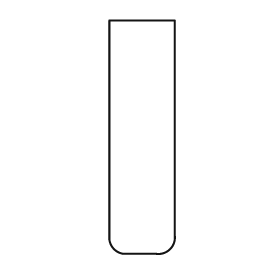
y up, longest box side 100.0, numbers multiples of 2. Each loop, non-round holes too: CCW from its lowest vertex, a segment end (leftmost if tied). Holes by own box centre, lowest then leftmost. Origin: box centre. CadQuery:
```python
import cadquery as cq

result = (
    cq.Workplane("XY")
    .moveTo(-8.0, -50.0)
    .lineTo(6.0, -50.0)
    .threePointArc((12.0, -48.0), (14.0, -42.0))
    .lineTo(14.0, 50.0)
    .lineTo(-14.0, 50.0)
    .lineTo(-14.0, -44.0)
    .threePointArc((-12.0, -48.0), (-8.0, -50.0))
    .close()
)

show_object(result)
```